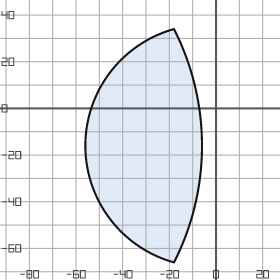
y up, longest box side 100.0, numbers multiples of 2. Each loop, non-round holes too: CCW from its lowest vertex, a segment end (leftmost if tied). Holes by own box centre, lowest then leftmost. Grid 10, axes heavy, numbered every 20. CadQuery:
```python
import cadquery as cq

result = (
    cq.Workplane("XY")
    .moveTo(-18.0, -66.0)
    .threePointArc((-6.0, -16.0), (-18.0, 34.0))
    .threePointArc((-56.0, -16.0), (-18.0, -66.0))
    .close()
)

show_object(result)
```